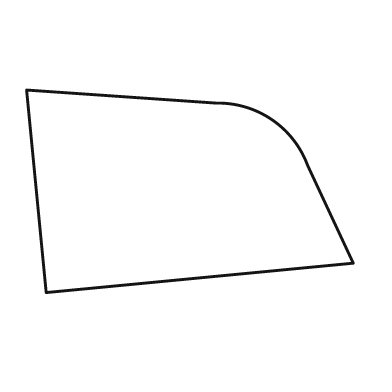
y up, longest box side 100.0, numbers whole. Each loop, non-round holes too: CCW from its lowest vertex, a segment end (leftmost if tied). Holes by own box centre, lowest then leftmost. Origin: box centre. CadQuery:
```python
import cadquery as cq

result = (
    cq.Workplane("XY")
    .moveTo(-44.0, -31.0)
    .lineTo(50.0, -22.0)
    .lineTo(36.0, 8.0)
    .threePointArc((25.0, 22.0), (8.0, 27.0))
    .lineTo(-50.0, 31.0)
    .close()
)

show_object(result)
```